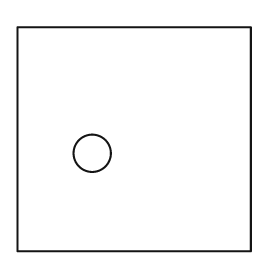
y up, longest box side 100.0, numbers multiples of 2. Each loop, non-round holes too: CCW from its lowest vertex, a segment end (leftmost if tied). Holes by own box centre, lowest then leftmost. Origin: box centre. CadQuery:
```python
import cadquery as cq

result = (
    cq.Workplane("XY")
    .moveTo(-50.0, -48.0)
    .lineTo(50.0, -48.0)
    .lineTo(50.0, 48.0)
    .lineTo(-50.0, 48.0)
    .close()
    .moveTo(-18.0, -6.0)
    .circle(8.0)
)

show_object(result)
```